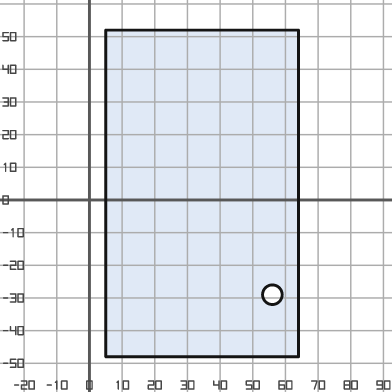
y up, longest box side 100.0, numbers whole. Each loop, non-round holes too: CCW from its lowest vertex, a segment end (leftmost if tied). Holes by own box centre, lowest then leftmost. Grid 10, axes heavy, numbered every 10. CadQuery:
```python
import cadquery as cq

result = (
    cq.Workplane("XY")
    .moveTo(5.0, -48.0)
    .lineTo(64.0, -48.0)
    .lineTo(64.0, 52.0)
    .lineTo(5.0, 52.0)
    .close()
    .moveTo(56.0, -29.0)
    .circle(3.0)
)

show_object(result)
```